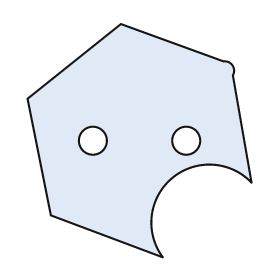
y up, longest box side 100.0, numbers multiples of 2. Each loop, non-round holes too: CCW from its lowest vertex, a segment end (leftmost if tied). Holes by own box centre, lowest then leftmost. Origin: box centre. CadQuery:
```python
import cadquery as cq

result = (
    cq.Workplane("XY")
    .moveTo(10.0, -50.0)
    .threePointArc((14.0, -16.0), (48.0, -18.0))
    .lineTo(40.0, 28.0)
    .threePointArc((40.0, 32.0), (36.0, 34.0))
    .lineTo(-8.0, 50.0)
    .lineTo(-48.0, 18.0)
    .lineTo(-38.0, -32.0)
    .close()
    .moveTo(-20.0, 0.0)
    .circle(6.0)
    .moveTo(20.0, 0.0)
    .circle(6.0)
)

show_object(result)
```